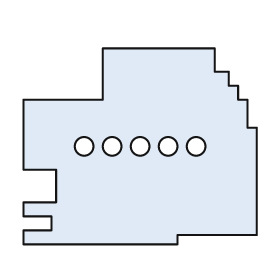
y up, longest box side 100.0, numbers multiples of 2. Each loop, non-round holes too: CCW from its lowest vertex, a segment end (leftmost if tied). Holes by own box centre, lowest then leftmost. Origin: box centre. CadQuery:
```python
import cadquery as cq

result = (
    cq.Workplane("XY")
    .moveTo(-50.0, -42.0)
    .lineTo(16.0, -42.0)
    .lineTo(16.0, -38.0)
    .lineTo(50.0, -38.0)
    .lineTo(50.0, 8.0)
    .lineTo(46.0, 8.0)
    .lineTo(46.0, 20.0)
    .lineTo(42.0, 20.0)
    .lineTo(42.0, 26.0)
    .lineTo(38.0, 26.0)
    .lineTo(38.0, 32.0)
    .lineTo(32.0, 32.0)
    .lineTo(32.0, 42.0)
    .lineTo(-16.0, 42.0)
    .lineTo(-16.0, 20.0)
    .lineTo(-50.0, 20.0)
    .lineTo(-50.0, -10.0)
    .lineTo(-36.0, -10.0)
    .lineTo(-36.0, -24.0)
    .lineTo(-50.0, -24.0)
    .lineTo(-50.0, -30.0)
    .lineTo(-38.0, -30.0)
    .lineTo(-38.0, -36.0)
    .lineTo(-50.0, -36.0)
    .close()
    .moveTo(-24.0, 0.0)
    .circle(4.0)
    .moveTo(-12.0, 0.0)
    .circle(4.0)
    .moveTo(0.0, 0.0)
    .circle(4.0)
    .moveTo(12.0, 0.0)
    .circle(4.0)
    .moveTo(24.0, 0.0)
    .circle(4.0)
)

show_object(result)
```